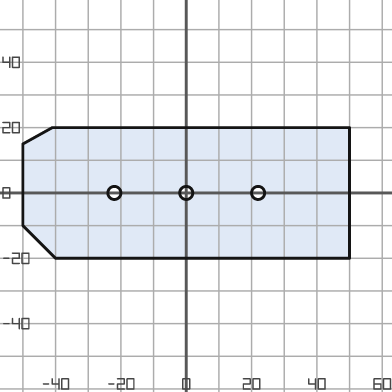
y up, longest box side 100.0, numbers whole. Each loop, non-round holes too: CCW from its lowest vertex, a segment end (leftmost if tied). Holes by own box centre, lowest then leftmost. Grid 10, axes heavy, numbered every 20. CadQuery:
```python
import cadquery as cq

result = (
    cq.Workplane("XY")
    .moveTo(-40.0, -20.0)
    .lineTo(50.0, -20.0)
    .lineTo(50.0, 20.0)
    .lineTo(-41.0, 20.0)
    .lineTo(-50.0, 15.0)
    .lineTo(-50.0, -10.0)
    .close()
    .moveTo(-22.0, 0.0)
    .circle(2.0)
    .moveTo(0.0, 0.0)
    .circle(2.0)
    .moveTo(22.0, 0.0)
    .circle(2.0)
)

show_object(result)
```